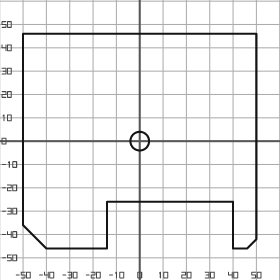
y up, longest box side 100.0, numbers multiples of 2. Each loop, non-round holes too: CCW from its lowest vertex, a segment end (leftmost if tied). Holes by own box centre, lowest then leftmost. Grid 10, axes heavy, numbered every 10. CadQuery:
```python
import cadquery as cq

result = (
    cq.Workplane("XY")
    .moveTo(-40.0, -46.0)
    .lineTo(-14.0, -46.0)
    .lineTo(-14.0, -26.0)
    .lineTo(40.0, -26.0)
    .lineTo(40.0, -46.0)
    .lineTo(46.0, -46.0)
    .lineTo(50.0, -42.0)
    .lineTo(50.0, 46.0)
    .lineTo(-50.0, 46.0)
    .lineTo(-50.0, -36.0)
    .close()
    .moveTo(0.0, 0.0)
    .circle(4.0)
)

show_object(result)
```